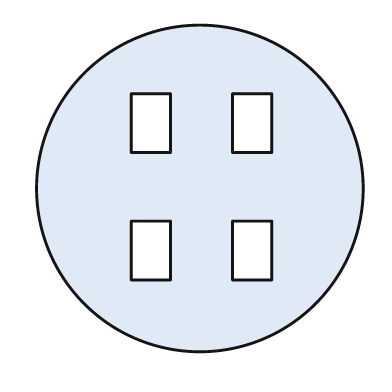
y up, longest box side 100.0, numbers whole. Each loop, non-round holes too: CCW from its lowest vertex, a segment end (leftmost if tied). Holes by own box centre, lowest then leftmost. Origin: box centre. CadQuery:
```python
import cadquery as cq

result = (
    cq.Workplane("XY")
    .moveTo(0.0, 0.0)
    .circle(50.0)
    .moveTo(-21.0, -28.0)
    .lineTo(-9.0, -28.0)
    .lineTo(-9.0, -10.0)
    .lineTo(-21.0, -10.0)
    .close()
    .moveTo(10.0, -28.0)
    .lineTo(22.0, -28.0)
    .lineTo(22.0, -10.0)
    .lineTo(10.0, -10.0)
    .close()
    .moveTo(-21.0, 11.0)
    .lineTo(-9.0, 11.0)
    .lineTo(-9.0, 29.0)
    .lineTo(-21.0, 29.0)
    .close()
    .moveTo(10.0, 11.0)
    .lineTo(22.0, 11.0)
    .lineTo(22.0, 29.0)
    .lineTo(10.0, 29.0)
    .close()
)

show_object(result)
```